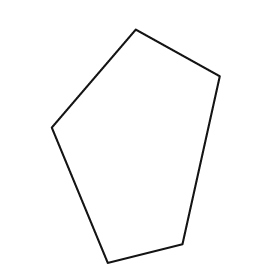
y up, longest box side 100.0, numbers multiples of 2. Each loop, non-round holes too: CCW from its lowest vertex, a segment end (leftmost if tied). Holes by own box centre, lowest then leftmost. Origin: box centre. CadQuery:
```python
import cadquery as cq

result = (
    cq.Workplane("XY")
    .moveTo(-12.0, -50.0)
    .lineTo(20.0, -42.0)
    .lineTo(36.0, 30.0)
    .lineTo(0.0, 50.0)
    .lineTo(-36.0, 8.0)
    .close()
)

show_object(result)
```